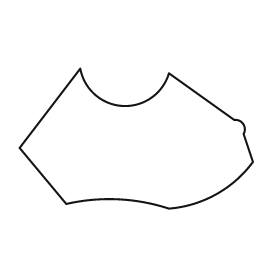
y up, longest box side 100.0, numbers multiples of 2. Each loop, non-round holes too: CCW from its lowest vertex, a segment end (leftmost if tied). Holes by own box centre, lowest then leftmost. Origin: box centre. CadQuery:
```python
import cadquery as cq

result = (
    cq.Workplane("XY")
    .moveTo(14.0, -30.0)
    .threePointArc((34.0, -24.0), (50.0, -10.0))
    .lineTo(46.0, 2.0)
    .threePointArc((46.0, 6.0), (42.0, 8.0))
    .lineTo(14.0, 28.0)
    .threePointArc((-6.0, 14.0), (-24.0, 30.0))
    .lineTo(-50.0, -4.0)
    .lineTo(-30.0, -28.0)
    .threePointArc((-8.0, -26.0), (14.0, -30.0))
    .close()
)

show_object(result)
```